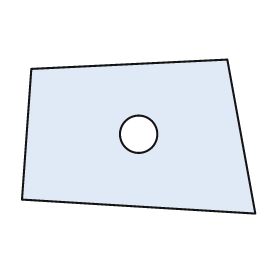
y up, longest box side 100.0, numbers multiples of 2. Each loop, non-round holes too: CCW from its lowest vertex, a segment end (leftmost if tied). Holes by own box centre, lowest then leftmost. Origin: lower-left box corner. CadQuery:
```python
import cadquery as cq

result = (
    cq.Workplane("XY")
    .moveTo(100.0, 0.0)
    .lineTo(88.0, 66.0)
    .lineTo(4.0, 62.0)
    .lineTo(0.0, 6.0)
    .close()
    .moveTo(50.0, 34.0)
    .circle(8.0)
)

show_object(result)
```